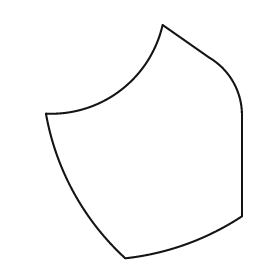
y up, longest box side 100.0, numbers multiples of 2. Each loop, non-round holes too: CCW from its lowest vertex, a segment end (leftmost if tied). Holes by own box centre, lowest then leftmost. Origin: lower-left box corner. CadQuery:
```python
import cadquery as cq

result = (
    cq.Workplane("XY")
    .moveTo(34.0, 0.0)
    .threePointArc((60.0, 6.0), (84.0, 18.0))
    .lineTo(84.0, 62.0)
    .threePointArc((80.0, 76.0), (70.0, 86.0))
    .lineTo(50.0, 100.0)
    .threePointArc((32.0, 72.0), (0.0, 62.0))
    .threePointArc((12.0, 28.0), (34.0, 0.0))
    .close()
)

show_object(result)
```